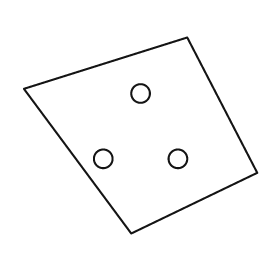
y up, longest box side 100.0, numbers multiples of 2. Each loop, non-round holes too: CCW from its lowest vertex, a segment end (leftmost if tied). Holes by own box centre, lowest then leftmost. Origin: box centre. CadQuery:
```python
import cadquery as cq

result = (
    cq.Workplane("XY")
    .moveTo(-4.0, -42.0)
    .lineTo(50.0, -16.0)
    .lineTo(20.0, 42.0)
    .lineTo(-50.0, 20.0)
    .close()
    .moveTo(-16.0, -10.0)
    .circle(4.0)
    .moveTo(16.0, -10.0)
    .circle(4.0)
    .moveTo(0.0, 18.0)
    .circle(4.0)
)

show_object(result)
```